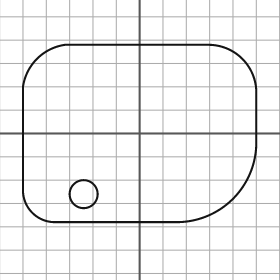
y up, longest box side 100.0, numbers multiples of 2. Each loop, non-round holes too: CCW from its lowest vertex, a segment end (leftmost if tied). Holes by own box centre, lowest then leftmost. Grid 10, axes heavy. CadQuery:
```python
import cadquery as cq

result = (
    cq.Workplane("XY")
    .moveTo(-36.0, -38.0)
    .lineTo(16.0, -38.0)
    .threePointArc((40.0, -28.0), (50.0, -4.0))
    .lineTo(50.0, 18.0)
    .threePointArc((44.0, 32.0), (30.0, 38.0))
    .lineTo(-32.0, 38.0)
    .threePointArc((-44.0, 32.0), (-50.0, 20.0))
    .lineTo(-50.0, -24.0)
    .threePointArc((-46.0, -34.0), (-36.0, -38.0))
    .close()
    .moveTo(-24.0, -26.0)
    .circle(6.0)
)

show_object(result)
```